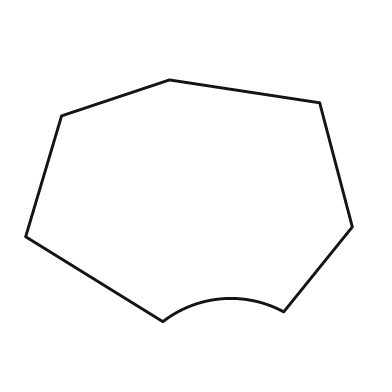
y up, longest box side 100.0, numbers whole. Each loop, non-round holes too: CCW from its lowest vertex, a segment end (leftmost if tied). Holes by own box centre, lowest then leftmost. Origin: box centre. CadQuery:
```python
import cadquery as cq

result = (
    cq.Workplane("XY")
    .moveTo(-8.0, -37.0)
    .threePointArc((10.0, -30.0), (29.0, -34.0))
    .lineTo(50.0, -8.0)
    .lineTo(40.0, 30.0)
    .lineTo(-6.0, 37.0)
    .lineTo(-39.0, 26.0)
    .lineTo(-50.0, -11.0)
    .close()
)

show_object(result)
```